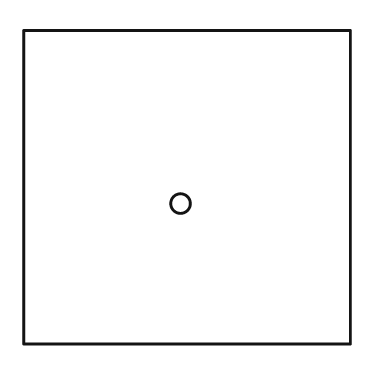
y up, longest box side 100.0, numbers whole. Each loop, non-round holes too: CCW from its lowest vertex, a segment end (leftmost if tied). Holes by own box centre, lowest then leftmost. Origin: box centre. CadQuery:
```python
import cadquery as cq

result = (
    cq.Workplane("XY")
    .moveTo(-50.0, -48.0)
    .lineTo(50.0, -48.0)
    .lineTo(50.0, 48.0)
    .lineTo(-50.0, 48.0)
    .close()
    .moveTo(-2.0, -5.0)
    .circle(3.0)
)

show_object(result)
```